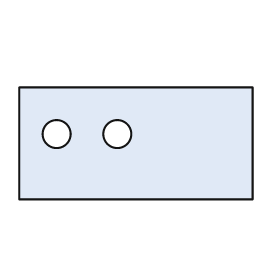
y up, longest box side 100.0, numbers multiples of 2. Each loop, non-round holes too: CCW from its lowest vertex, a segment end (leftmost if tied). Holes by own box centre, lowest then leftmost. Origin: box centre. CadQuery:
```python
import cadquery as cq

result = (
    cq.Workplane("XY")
    .moveTo(-50.0, -24.0)
    .lineTo(50.0, -24.0)
    .lineTo(50.0, 24.0)
    .lineTo(-50.0, 24.0)
    .close()
    .moveTo(-34.0, 4.0)
    .circle(6.0)
    .moveTo(-8.0, 4.0)
    .circle(6.0)
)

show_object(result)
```